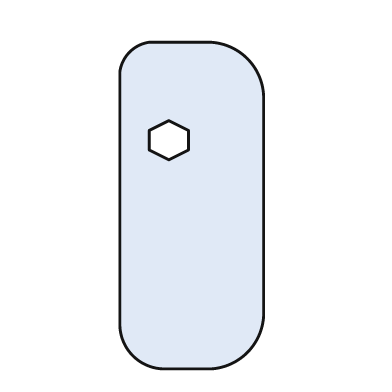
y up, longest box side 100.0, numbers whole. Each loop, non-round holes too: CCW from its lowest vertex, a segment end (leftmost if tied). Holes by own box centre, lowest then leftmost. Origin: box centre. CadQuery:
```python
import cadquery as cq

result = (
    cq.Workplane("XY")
    .moveTo(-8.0, -50.0)
    .lineTo(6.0, -50.0)
    .threePointArc((17.0, -45.0), (22.0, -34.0))
    .lineTo(22.0, 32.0)
    .threePointArc((17.0, 45.0), (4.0, 50.0))
    .lineTo(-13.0, 50.0)
    .threePointArc((-19.0, 47.0), (-22.0, 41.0))
    .lineTo(-22.0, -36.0)
    .threePointArc((-18.0, -46.0), (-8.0, -50.0))
    .close()
    .moveTo(-7.0, 14.0)
    .lineTo(-1.0, 17.0)
    .lineTo(-1.0, 23.0)
    .lineTo(-7.0, 26.0)
    .lineTo(-13.0, 23.0)
    .lineTo(-13.0, 17.0)
    .close()
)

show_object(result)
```